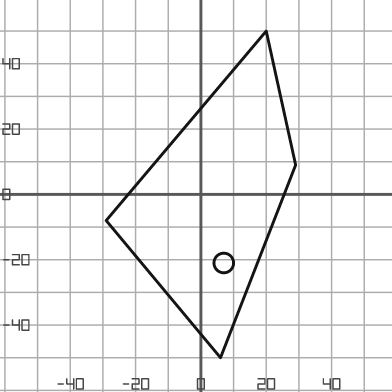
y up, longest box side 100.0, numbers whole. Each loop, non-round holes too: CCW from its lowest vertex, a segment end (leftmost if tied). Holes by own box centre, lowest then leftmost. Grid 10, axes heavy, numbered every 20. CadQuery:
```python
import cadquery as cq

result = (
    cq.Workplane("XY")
    .moveTo(6.0, -50.0)
    .lineTo(29.0, 9.0)
    .lineTo(20.0, 50.0)
    .lineTo(-29.0, -8.0)
    .close()
    .moveTo(7.0, -21.0)
    .circle(3.0)
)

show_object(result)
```